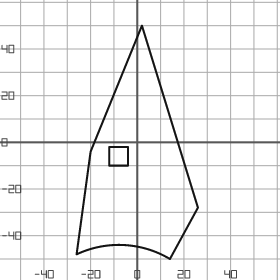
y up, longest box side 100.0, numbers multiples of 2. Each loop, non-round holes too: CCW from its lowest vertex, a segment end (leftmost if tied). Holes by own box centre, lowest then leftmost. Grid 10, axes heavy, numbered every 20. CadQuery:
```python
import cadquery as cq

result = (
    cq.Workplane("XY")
    .moveTo(14.0, -50.0)
    .lineTo(26.0, -28.0)
    .lineTo(2.0, 50.0)
    .lineTo(-20.0, -4.0)
    .lineTo(-26.0, -48.0)
    .threePointArc((-6.0, -44.0), (14.0, -50.0))
    .close()
    .moveTo(-12.0, -10.0)
    .lineTo(-4.0, -10.0)
    .lineTo(-4.0, -2.0)
    .lineTo(-12.0, -2.0)
    .close()
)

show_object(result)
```